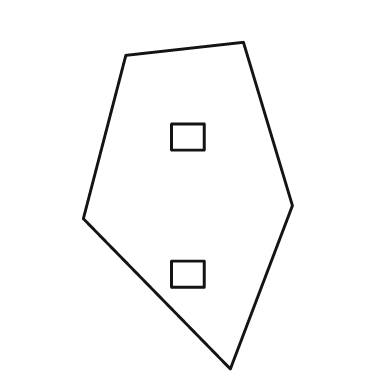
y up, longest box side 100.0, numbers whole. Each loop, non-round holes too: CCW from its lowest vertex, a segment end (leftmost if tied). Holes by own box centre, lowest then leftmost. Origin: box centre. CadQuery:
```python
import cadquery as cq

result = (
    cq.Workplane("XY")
    .moveTo(13.0, -50.0)
    .lineTo(32.0, 0.0)
    .lineTo(17.0, 50.0)
    .lineTo(-19.0, 46.0)
    .lineTo(-32.0, -4.0)
    .close()
    .moveTo(-5.0, -25.0)
    .lineTo(5.0, -25.0)
    .lineTo(5.0, -17.0)
    .lineTo(-5.0, -17.0)
    .close()
    .moveTo(-5.0, 17.0)
    .lineTo(5.0, 17.0)
    .lineTo(5.0, 25.0)
    .lineTo(-5.0, 25.0)
    .close()
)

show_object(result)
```